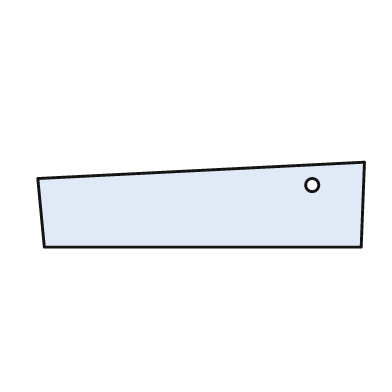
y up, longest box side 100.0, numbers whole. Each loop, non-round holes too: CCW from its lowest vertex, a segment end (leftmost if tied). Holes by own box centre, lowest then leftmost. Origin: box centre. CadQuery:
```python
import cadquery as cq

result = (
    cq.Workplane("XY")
    .moveTo(-48.0, -13.0)
    .lineTo(49.0, -13.0)
    .lineTo(50.0, 13.0)
    .lineTo(-50.0, 8.0)
    .close()
    .moveTo(34.0, 6.0)
    .circle(2.0)
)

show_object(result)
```